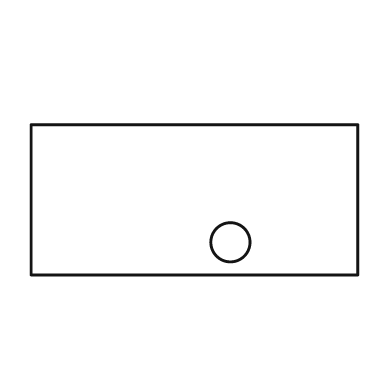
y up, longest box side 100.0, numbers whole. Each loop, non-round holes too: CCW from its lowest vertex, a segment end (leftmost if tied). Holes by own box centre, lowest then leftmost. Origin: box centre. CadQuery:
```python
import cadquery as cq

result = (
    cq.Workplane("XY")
    .moveTo(-50.0, -23.0)
    .lineTo(50.0, -23.0)
    .lineTo(50.0, 23.0)
    .lineTo(-50.0, 23.0)
    .close()
    .moveTo(11.0, -13.0)
    .circle(6.0)
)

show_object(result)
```